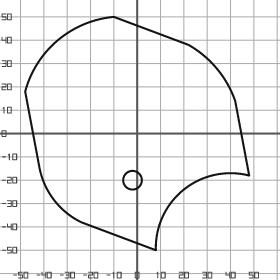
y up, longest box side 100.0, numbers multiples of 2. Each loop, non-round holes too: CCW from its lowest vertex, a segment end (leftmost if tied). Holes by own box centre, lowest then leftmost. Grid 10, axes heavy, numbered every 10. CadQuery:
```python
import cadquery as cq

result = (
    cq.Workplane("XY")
    .moveTo(8.0, -50.0)
    .threePointArc((20.0, -24.0), (48.0, -18.0))
    .lineTo(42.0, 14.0)
    .threePointArc((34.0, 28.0), (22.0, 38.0))
    .lineTo(-10.0, 50.0)
    .threePointArc((-34.0, 40.0), (-48.0, 18.0))
    .lineTo(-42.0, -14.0)
    .threePointArc((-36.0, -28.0), (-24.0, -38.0))
    .close()
    .moveTo(-2.0, -20.0)
    .circle(4.0)
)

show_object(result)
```